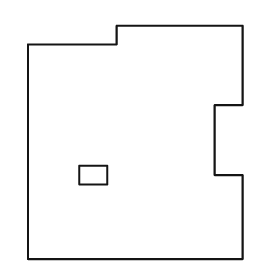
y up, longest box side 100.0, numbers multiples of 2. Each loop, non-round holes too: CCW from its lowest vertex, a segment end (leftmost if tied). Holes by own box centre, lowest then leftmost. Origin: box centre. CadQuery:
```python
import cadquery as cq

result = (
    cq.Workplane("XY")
    .moveTo(-46.0, -50.0)
    .lineTo(46.0, -50.0)
    .lineTo(46.0, -14.0)
    .lineTo(34.0, -14.0)
    .lineTo(34.0, 16.0)
    .lineTo(46.0, 16.0)
    .lineTo(46.0, 50.0)
    .lineTo(-8.0, 50.0)
    .lineTo(-8.0, 42.0)
    .lineTo(-46.0, 42.0)
    .close()
    .moveTo(-24.0, -18.0)
    .lineTo(-12.0, -18.0)
    .lineTo(-12.0, -10.0)
    .lineTo(-24.0, -10.0)
    .close()
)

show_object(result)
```